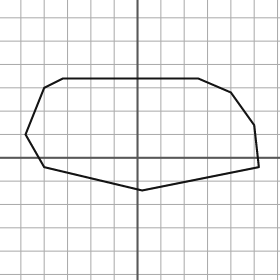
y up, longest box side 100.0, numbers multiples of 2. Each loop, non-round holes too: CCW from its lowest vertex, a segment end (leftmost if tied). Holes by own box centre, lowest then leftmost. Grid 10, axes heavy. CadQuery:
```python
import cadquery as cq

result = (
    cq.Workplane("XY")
    .moveTo(2.0, -14.0)
    .lineTo(52.0, -4.0)
    .lineTo(50.0, 14.0)
    .lineTo(40.0, 28.0)
    .lineTo(26.0, 34.0)
    .lineTo(-32.0, 34.0)
    .lineTo(-40.0, 30.0)
    .lineTo(-48.0, 10.0)
    .lineTo(-40.0, -4.0)
    .close()
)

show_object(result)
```